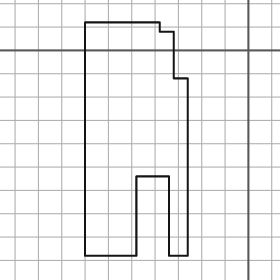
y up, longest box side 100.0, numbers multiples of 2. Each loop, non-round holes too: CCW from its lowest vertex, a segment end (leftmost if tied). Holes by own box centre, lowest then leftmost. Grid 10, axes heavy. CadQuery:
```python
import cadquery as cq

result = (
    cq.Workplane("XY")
    .moveTo(-70.0, -88.0)
    .lineTo(-48.0, -88.0)
    .lineTo(-48.0, -54.0)
    .lineTo(-34.0, -54.0)
    .lineTo(-34.0, -88.0)
    .lineTo(-26.0, -88.0)
    .lineTo(-26.0, -12.0)
    .lineTo(-32.0, -12.0)
    .lineTo(-32.0, 8.0)
    .lineTo(-38.0, 8.0)
    .lineTo(-38.0, 12.0)
    .lineTo(-70.0, 12.0)
    .close()
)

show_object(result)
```